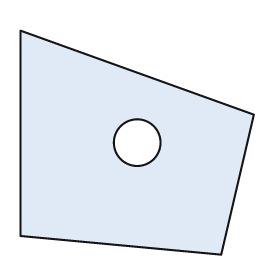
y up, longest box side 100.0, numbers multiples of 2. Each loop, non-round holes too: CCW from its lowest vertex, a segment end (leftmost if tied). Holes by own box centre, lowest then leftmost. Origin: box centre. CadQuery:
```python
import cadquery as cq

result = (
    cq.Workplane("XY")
    .moveTo(36.0, -48.0)
    .lineTo(50.0, 12.0)
    .lineTo(-50.0, 48.0)
    .lineTo(-50.0, -40.0)
    .close()
    .moveTo(0.0, 0.0)
    .circle(10.0)
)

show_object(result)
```